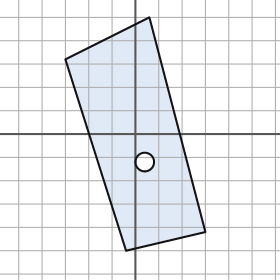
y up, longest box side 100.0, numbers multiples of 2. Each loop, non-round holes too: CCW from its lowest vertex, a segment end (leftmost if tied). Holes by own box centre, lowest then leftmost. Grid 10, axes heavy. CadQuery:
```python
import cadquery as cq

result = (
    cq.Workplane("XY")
    .moveTo(-4.0, -50.0)
    .lineTo(30.0, -42.0)
    .lineTo(6.0, 50.0)
    .lineTo(-30.0, 32.0)
    .close()
    .moveTo(4.0, -12.0)
    .circle(4.0)
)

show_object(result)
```